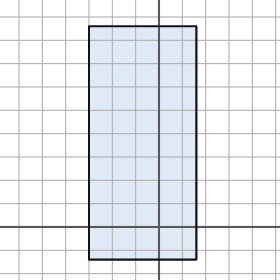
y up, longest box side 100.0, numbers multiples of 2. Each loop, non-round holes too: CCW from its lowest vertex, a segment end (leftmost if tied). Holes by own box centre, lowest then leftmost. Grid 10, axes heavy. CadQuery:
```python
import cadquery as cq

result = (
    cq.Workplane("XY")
    .moveTo(-30.0, -14.0)
    .lineTo(16.0, -14.0)
    .lineTo(16.0, 86.0)
    .lineTo(-30.0, 86.0)
    .close()
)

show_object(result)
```